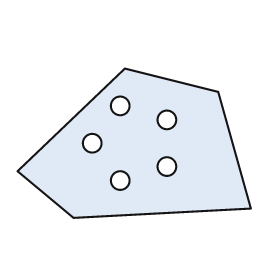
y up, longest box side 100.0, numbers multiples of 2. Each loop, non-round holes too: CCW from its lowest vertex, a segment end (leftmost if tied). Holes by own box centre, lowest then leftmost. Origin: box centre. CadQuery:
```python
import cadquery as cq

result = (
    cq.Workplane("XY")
    .moveTo(-26.0, -32.0)
    .lineTo(50.0, -28.0)
    .lineTo(36.0, 22.0)
    .lineTo(-4.0, 32.0)
    .lineTo(-50.0, -12.0)
    .close()
    .moveTo(-6.0, -16.0)
    .circle(4.0)
    .moveTo(14.0, -10.0)
    .circle(4.0)
    .moveTo(-18.0, 0.0)
    .circle(4.0)
    .moveTo(14.0, 10.0)
    .circle(4.0)
    .moveTo(-6.0, 16.0)
    .circle(4.0)
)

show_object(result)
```